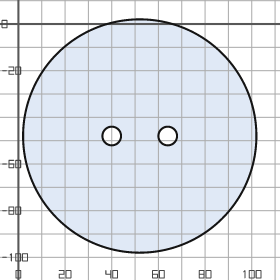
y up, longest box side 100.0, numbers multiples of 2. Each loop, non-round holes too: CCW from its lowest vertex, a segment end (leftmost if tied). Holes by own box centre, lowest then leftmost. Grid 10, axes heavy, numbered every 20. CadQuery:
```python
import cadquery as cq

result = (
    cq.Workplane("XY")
    .moveTo(52.0, -48.0)
    .circle(50.0)
    .moveTo(40.0, -48.0)
    .circle(4.0)
    .moveTo(64.0, -48.0)
    .circle(4.0)
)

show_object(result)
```